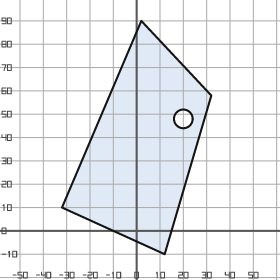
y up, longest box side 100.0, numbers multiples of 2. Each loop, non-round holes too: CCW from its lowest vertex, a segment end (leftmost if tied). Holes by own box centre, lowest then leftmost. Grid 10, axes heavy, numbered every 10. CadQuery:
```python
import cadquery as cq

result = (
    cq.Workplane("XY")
    .moveTo(12.0, -10.0)
    .lineTo(32.0, 58.0)
    .lineTo(2.0, 90.0)
    .lineTo(-32.0, 10.0)
    .close()
    .moveTo(20.0, 48.0)
    .circle(4.0)
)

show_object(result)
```